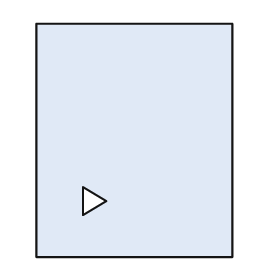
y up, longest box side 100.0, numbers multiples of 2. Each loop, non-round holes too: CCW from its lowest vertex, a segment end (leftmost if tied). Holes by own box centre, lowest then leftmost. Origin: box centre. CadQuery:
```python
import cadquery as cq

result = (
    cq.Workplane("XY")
    .moveTo(-42.0, -50.0)
    .lineTo(42.0, -50.0)
    .lineTo(42.0, 50.0)
    .lineTo(-42.0, 50.0)
    .close()
    .moveTo(-22.0, -32.0)
    .lineTo(-12.0, -26.0)
    .lineTo(-22.0, -20.0)
    .close()
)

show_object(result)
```